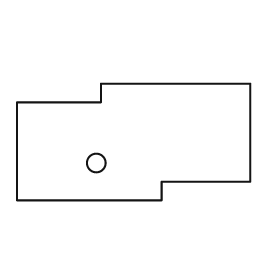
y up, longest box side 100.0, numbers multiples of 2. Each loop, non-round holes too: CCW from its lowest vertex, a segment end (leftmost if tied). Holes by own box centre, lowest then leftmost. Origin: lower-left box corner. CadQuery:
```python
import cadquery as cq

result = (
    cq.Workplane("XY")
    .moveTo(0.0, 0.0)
    .lineTo(62.0, 0.0)
    .lineTo(62.0, 8.0)
    .lineTo(100.0, 8.0)
    .lineTo(100.0, 50.0)
    .lineTo(36.0, 50.0)
    .lineTo(36.0, 42.0)
    .lineTo(0.0, 42.0)
    .close()
    .moveTo(34.0, 16.0)
    .circle(4.0)
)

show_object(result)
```